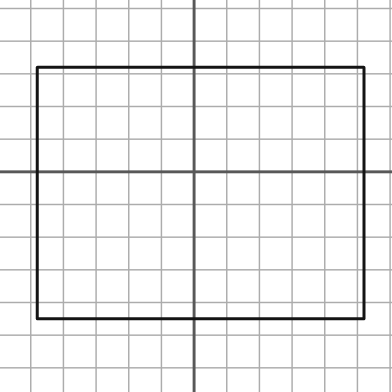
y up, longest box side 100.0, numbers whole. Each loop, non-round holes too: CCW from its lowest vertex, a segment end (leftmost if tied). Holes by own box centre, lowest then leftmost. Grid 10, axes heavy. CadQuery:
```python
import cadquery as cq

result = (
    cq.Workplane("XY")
    .moveTo(-48.0, -45.0)
    .lineTo(52.0, -45.0)
    .lineTo(52.0, 32.0)
    .lineTo(-48.0, 32.0)
    .close()
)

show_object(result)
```